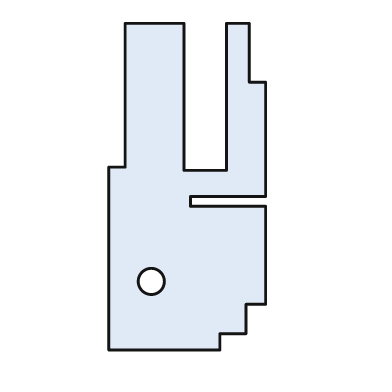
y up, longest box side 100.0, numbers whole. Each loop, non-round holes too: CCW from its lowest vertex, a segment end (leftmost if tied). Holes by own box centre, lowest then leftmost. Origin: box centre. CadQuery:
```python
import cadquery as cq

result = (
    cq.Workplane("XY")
    .moveTo(-24.0, -50.0)
    .lineTo(10.0, -50.0)
    .lineTo(10.0, -45.0)
    .lineTo(18.0, -45.0)
    .lineTo(18.0, -36.0)
    .lineTo(24.0, -36.0)
    .lineTo(24.0, -6.0)
    .lineTo(1.0, -6.0)
    .lineTo(1.0, -3.0)
    .lineTo(24.0, -3.0)
    .lineTo(24.0, 32.0)
    .lineTo(19.0, 32.0)
    .lineTo(19.0, 50.0)
    .lineTo(12.0, 50.0)
    .lineTo(12.0, 5.0)
    .lineTo(-1.0, 5.0)
    .lineTo(-1.0, 50.0)
    .lineTo(-19.0, 50.0)
    .lineTo(-19.0, 6.0)
    .lineTo(-24.0, 6.0)
    .close()
    .moveTo(-11.0, -29.0)
    .circle(4.0)
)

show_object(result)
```